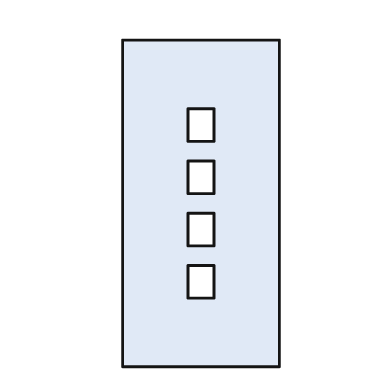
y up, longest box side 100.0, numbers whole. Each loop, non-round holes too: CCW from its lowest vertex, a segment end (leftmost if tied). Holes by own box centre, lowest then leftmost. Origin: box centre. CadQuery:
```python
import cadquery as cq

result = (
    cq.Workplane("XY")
    .moveTo(-24.0, -50.0)
    .lineTo(24.0, -50.0)
    .lineTo(24.0, 50.0)
    .lineTo(-24.0, 50.0)
    .close()
    .moveTo(-4.0, -29.0)
    .lineTo(4.0, -29.0)
    .lineTo(4.0, -19.0)
    .lineTo(-4.0, -19.0)
    .close()
    .moveTo(-4.0, -13.0)
    .lineTo(4.0, -13.0)
    .lineTo(4.0, -3.0)
    .lineTo(-4.0, -3.0)
    .close()
    .moveTo(-4.0, 3.0)
    .lineTo(4.0, 3.0)
    .lineTo(4.0, 13.0)
    .lineTo(-4.0, 13.0)
    .close()
    .moveTo(-4.0, 19.0)
    .lineTo(4.0, 19.0)
    .lineTo(4.0, 29.0)
    .lineTo(-4.0, 29.0)
    .close()
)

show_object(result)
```